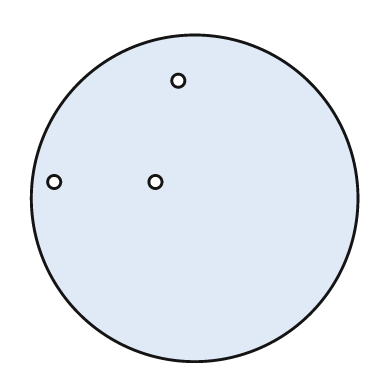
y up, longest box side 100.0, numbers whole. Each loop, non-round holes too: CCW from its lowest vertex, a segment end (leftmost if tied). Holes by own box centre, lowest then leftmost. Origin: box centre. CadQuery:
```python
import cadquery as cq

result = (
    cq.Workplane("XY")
    .moveTo(0.0, 0.0)
    .circle(50.0)
    .moveTo(-43.0, 5.0)
    .circle(2.0)
    .moveTo(-12.0, 5.0)
    .circle(2.0)
    .moveTo(-5.0, 36.0)
    .circle(2.0)
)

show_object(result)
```